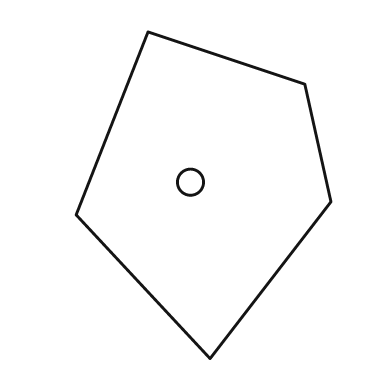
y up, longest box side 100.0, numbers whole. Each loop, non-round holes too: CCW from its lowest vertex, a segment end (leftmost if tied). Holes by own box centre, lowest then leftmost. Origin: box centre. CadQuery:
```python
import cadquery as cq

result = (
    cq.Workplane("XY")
    .moveTo(2.0, -50.0)
    .lineTo(39.0, -2.0)
    .lineTo(31.0, 34.0)
    .lineTo(-17.0, 50.0)
    .lineTo(-39.0, -6.0)
    .close()
    .moveTo(-4.0, 4.0)
    .circle(4.0)
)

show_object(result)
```